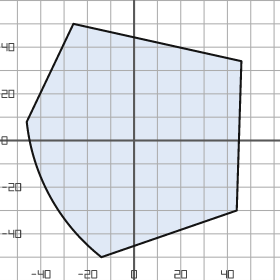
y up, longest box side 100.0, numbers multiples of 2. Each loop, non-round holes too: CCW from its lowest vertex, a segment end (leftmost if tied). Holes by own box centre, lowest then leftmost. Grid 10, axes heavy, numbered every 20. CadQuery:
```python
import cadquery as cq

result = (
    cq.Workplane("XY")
    .moveTo(-14.0, -50.0)
    .lineTo(44.0, -30.0)
    .lineTo(46.0, 34.0)
    .lineTo(-26.0, 50.0)
    .lineTo(-46.0, 8.0)
    .threePointArc((-36.0, -24.0), (-14.0, -50.0))
    .close()
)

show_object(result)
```